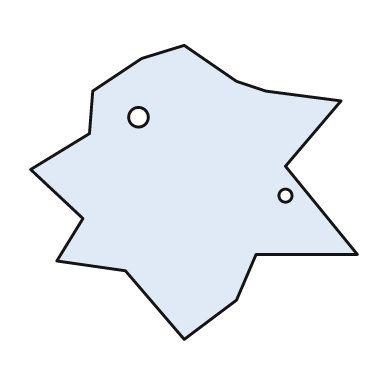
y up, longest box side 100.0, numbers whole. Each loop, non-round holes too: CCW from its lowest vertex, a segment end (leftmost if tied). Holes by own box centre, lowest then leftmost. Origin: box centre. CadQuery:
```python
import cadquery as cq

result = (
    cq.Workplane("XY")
    .moveTo(-3.0, -45.0)
    .lineTo(13.0, -33.0)
    .lineTo(19.0, -19.0)
    .lineTo(50.0, -19.0)
    .lineTo(28.0, 8.0)
    .lineTo(45.0, 28.0)
    .lineTo(22.0, 31.0)
    .lineTo(13.0, 34.0)
    .lineTo(-3.0, 45.0)
    .lineTo(-16.0, 41.0)
    .lineTo(-31.0, 31.0)
    .lineTo(-32.0, 18.0)
    .lineTo(-50.0, 7.0)
    .lineTo(-34.0, -8.0)
    .lineTo(-42.0, -21.0)
    .lineTo(-21.0, -24.0)
    .close()
    .moveTo(28.0, -1.0)
    .circle(2.0)
    .moveTo(-17.0, 23.0)
    .circle(3.0)
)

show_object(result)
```